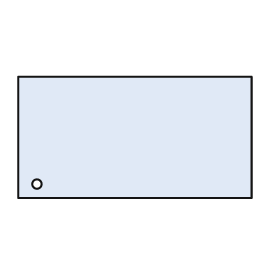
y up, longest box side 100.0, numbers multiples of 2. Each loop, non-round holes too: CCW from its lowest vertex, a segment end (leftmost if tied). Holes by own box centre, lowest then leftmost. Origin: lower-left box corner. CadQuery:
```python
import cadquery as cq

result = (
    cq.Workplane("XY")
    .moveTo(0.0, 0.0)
    .lineTo(100.0, 0.0)
    .lineTo(100.0, 52.0)
    .lineTo(0.0, 52.0)
    .close()
    .moveTo(8.0, 6.0)
    .circle(2.0)
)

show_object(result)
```